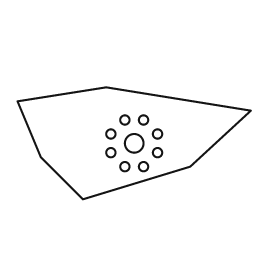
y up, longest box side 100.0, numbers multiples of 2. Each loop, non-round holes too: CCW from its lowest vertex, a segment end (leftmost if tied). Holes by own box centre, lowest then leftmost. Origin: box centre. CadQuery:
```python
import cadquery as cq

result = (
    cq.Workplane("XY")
    .moveTo(-22.0, -24.0)
    .lineTo(24.0, -10.0)
    .lineTo(50.0, 14.0)
    .lineTo(-12.0, 24.0)
    .lineTo(-50.0, 18.0)
    .lineTo(-40.0, -6.0)
    .close()
    .moveTo(-4.0, -10.0)
    .circle(2.0)
    .moveTo(4.0, -10.0)
    .circle(2.0)
    .moveTo(-10.0, -4.0)
    .circle(2.0)
    .moveTo(10.0, -4.0)
    .circle(2.0)
    .moveTo(0.0, 0.0)
    .circle(4.0)
    .moveTo(-10.0, 4.0)
    .circle(2.0)
    .moveTo(10.0, 4.0)
    .circle(2.0)
    .moveTo(-4.0, 10.0)
    .circle(2.0)
    .moveTo(4.0, 10.0)
    .circle(2.0)
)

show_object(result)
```